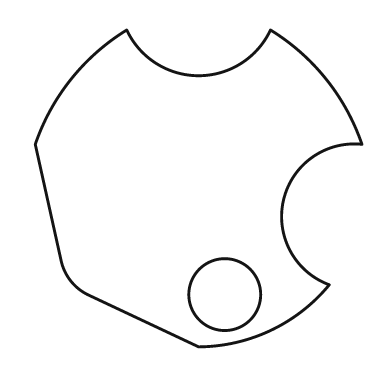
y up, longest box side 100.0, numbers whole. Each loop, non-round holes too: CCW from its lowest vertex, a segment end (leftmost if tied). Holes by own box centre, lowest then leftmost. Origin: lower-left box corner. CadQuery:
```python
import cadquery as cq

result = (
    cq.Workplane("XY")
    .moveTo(50.0, 0.0)
    .threePointArc((72.0, 5.0), (90.0, 19.0))
    .threePointArc((76.0, 45.0), (100.0, 62.0))
    .threePointArc((89.0, 82.0), (72.0, 97.0))
    .threePointArc((50.0, 83.0), (28.0, 97.0))
    .threePointArc((11.0, 82.0), (0.0, 62.0))
    .lineTo(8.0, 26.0)
    .threePointArc((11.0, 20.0), (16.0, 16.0))
    .close()
    .moveTo(58.0, 16.0)
    .circle(11.0)
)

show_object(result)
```